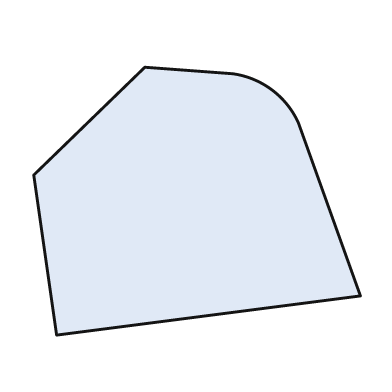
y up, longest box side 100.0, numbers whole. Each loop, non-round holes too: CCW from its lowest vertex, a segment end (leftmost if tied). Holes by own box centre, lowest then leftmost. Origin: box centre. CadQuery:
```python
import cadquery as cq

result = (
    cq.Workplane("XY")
    .moveTo(-43.0, -41.0)
    .lineTo(50.0, -29.0)
    .lineTo(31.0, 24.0)
    .threePointArc((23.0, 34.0), (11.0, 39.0))
    .lineTo(-16.0, 41.0)
    .lineTo(-50.0, 8.0)
    .close()
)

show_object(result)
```